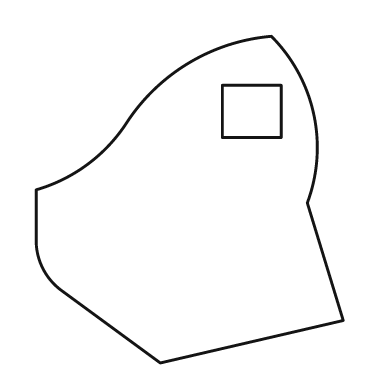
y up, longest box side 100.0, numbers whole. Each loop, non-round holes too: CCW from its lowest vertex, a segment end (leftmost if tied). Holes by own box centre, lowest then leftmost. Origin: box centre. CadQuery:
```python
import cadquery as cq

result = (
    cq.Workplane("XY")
    .moveTo(-9.0, -50.0)
    .lineTo(47.0, -37.0)
    .lineTo(36.0, -1.0)
    .threePointArc((38.0, 26.0), (25.0, 50.0))
    .threePointArc((0.0, 42.0), (-19.0, 24.0))
    .threePointArc((-31.0, 11.0), (-47.0, 3.0))
    .lineTo(-47.0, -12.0)
    .threePointArc((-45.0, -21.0), (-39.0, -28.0))
    .close()
    .moveTo(10.0, 19.0)
    .lineTo(28.0, 19.0)
    .lineTo(28.0, 35.0)
    .lineTo(10.0, 35.0)
    .close()
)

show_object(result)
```